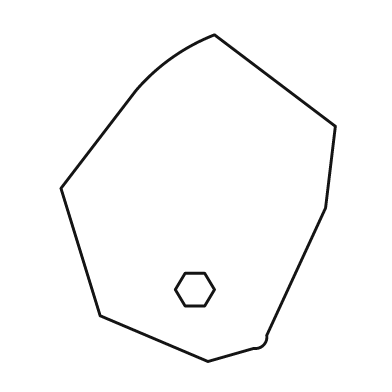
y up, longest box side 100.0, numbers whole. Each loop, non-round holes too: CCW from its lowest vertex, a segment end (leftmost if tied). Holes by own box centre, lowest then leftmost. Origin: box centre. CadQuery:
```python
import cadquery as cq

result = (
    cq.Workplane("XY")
    .moveTo(3.0, -50.0)
    .lineTo(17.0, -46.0)
    .threePointArc((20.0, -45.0), (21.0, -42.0))
    .lineTo(39.0, -3.0)
    .lineTo(42.0, 22.0)
    .lineTo(5.0, 50.0)
    .threePointArc((-8.0, 43.0), (-19.0, 33.0))
    .lineTo(-42.0, 3.0)
    .lineTo(-30.0, -36.0)
    .close()
    .moveTo(-4.0, -33.0)
    .lineTo(2.0, -33.0)
    .lineTo(5.0, -28.0)
    .lineTo(2.0, -23.0)
    .lineTo(-4.0, -23.0)
    .lineTo(-7.0, -28.0)
    .close()
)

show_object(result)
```